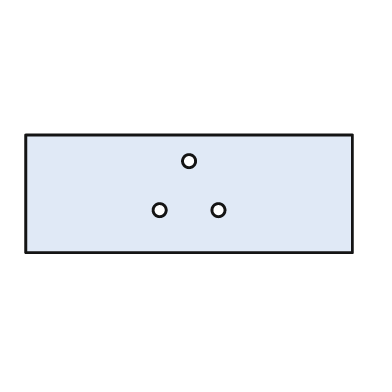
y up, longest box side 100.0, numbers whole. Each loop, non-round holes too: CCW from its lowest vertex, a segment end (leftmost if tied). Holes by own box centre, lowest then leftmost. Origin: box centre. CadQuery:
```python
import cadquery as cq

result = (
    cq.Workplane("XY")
    .moveTo(-50.0, -18.0)
    .lineTo(50.0, -18.0)
    .lineTo(50.0, 18.0)
    .lineTo(-50.0, 18.0)
    .close()
    .moveTo(-9.0, -5.0)
    .circle(2.0)
    .moveTo(9.0, -5.0)
    .circle(2.0)
    .moveTo(0.0, 10.0)
    .circle(2.0)
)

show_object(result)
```